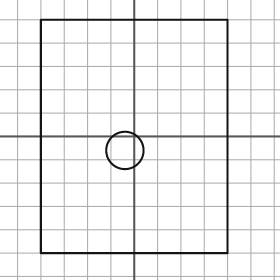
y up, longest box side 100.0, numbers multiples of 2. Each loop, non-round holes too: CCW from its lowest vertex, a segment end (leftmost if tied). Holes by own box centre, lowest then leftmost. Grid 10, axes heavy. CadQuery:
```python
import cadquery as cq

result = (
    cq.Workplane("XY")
    .moveTo(-40.0, -50.0)
    .lineTo(40.0, -50.0)
    .lineTo(40.0, 50.0)
    .lineTo(-40.0, 50.0)
    .close()
    .moveTo(-4.0, -6.0)
    .circle(8.0)
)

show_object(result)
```